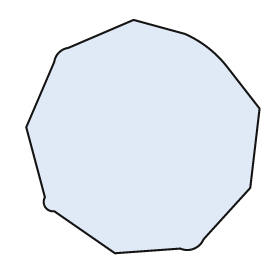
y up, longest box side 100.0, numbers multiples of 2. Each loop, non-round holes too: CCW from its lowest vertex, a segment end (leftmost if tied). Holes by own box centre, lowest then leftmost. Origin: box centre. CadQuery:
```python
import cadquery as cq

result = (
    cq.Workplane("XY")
    .moveTo(-12.0, -50.0)
    .lineTo(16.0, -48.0)
    .threePointArc((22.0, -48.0), (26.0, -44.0))
    .lineTo(46.0, -22.0)
    .lineTo(50.0, 12.0)
    .lineTo(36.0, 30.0)
    .threePointArc((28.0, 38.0), (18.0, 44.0))
    .lineTo(-4.0, 50.0)
    .lineTo(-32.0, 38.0)
    .threePointArc((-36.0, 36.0), (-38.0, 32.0))
    .lineTo(-50.0, 4.0)
    .lineTo(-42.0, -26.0)
    .threePointArc((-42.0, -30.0), (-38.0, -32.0))
    .close()
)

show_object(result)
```